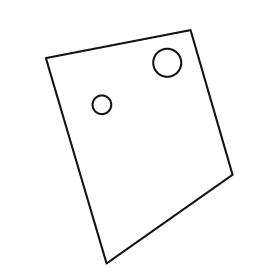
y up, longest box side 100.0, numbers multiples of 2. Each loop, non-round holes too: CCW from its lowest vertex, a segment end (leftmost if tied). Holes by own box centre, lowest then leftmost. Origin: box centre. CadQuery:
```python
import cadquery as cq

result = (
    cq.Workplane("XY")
    .moveTo(-14.0, -50.0)
    .lineTo(40.0, -12.0)
    .lineTo(22.0, 50.0)
    .lineTo(-40.0, 38.0)
    .close()
    .moveTo(-16.0, 18.0)
    .circle(4.0)
    .moveTo(12.0, 36.0)
    .circle(6.0)
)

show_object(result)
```